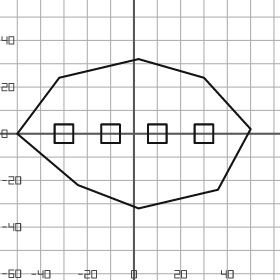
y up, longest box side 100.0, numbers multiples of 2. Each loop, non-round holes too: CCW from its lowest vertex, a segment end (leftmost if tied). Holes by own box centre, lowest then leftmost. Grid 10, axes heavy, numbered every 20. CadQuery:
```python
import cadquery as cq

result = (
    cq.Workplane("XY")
    .moveTo(2.0, -32.0)
    .lineTo(36.0, -24.0)
    .lineTo(50.0, 2.0)
    .lineTo(30.0, 24.0)
    .lineTo(2.0, 32.0)
    .lineTo(-32.0, 24.0)
    .lineTo(-50.0, 0.0)
    .lineTo(-24.0, -22.0)
    .close()
    .moveTo(-34.0, -4.0)
    .lineTo(-26.0, -4.0)
    .lineTo(-26.0, 4.0)
    .lineTo(-34.0, 4.0)
    .close()
    .moveTo(-14.0, -4.0)
    .lineTo(-6.0, -4.0)
    .lineTo(-6.0, 4.0)
    .lineTo(-14.0, 4.0)
    .close()
    .moveTo(6.0, -4.0)
    .lineTo(14.0, -4.0)
    .lineTo(14.0, 4.0)
    .lineTo(6.0, 4.0)
    .close()
    .moveTo(26.0, -4.0)
    .lineTo(34.0, -4.0)
    .lineTo(34.0, 4.0)
    .lineTo(26.0, 4.0)
    .close()
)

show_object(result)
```